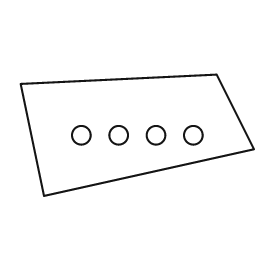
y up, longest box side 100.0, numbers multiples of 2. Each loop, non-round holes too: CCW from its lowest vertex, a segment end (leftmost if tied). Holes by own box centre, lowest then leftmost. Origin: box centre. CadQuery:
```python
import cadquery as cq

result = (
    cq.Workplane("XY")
    .moveTo(-40.0, -26.0)
    .lineTo(50.0, -6.0)
    .lineTo(34.0, 26.0)
    .lineTo(-50.0, 22.0)
    .close()
    .moveTo(-24.0, 0.0)
    .circle(4.0)
    .moveTo(-8.0, 0.0)
    .circle(4.0)
    .moveTo(8.0, 0.0)
    .circle(4.0)
    .moveTo(24.0, 0.0)
    .circle(4.0)
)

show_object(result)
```